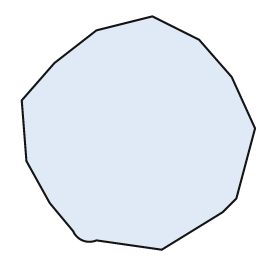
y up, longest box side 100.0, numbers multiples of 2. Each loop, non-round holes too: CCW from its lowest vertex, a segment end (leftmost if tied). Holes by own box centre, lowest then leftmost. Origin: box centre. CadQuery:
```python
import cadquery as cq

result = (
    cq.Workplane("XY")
    .moveTo(10.0, -50.0)
    .lineTo(36.0, -34.0)
    .lineTo(42.0, -28.0)
    .lineTo(50.0, 2.0)
    .lineTo(40.0, 24.0)
    .lineTo(26.0, 40.0)
    .lineTo(6.0, 50.0)
    .lineTo(-18.0, 44.0)
    .lineTo(-36.0, 30.0)
    .lineTo(-50.0, 14.0)
    .lineTo(-48.0, -12.0)
    .lineTo(-38.0, -30.0)
    .lineTo(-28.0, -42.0)
    .threePointArc((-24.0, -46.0), (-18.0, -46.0))
    .close()
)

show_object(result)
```